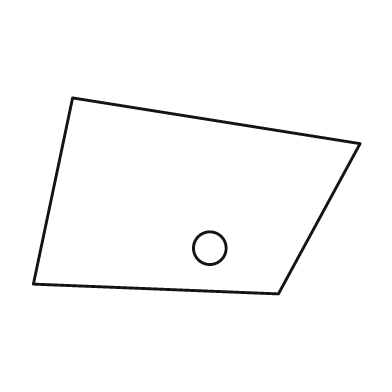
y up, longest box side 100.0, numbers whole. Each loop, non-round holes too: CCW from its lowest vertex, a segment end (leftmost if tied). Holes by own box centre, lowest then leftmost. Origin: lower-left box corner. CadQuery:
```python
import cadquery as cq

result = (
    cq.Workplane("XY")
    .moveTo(75.0, 0.0)
    .lineTo(100.0, 46.0)
    .lineTo(12.0, 60.0)
    .lineTo(0.0, 3.0)
    .close()
    .moveTo(54.0, 14.0)
    .circle(5.0)
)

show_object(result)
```